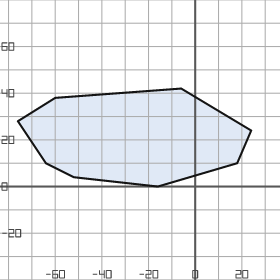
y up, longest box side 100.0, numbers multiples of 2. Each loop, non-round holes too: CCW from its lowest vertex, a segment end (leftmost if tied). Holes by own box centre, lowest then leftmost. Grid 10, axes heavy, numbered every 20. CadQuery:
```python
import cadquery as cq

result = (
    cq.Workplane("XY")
    .moveTo(-16.0, 0.0)
    .lineTo(18.0, 10.0)
    .lineTo(24.0, 24.0)
    .lineTo(-6.0, 42.0)
    .lineTo(-60.0, 38.0)
    .lineTo(-76.0, 28.0)
    .lineTo(-64.0, 10.0)
    .lineTo(-52.0, 4.0)
    .close()
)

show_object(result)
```